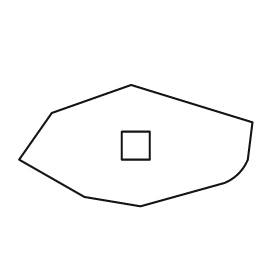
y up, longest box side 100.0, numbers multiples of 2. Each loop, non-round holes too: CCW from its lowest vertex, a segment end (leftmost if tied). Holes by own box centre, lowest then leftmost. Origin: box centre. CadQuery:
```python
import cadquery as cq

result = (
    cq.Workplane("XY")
    .moveTo(2.0, -26.0)
    .lineTo(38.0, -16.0)
    .threePointArc((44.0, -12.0), (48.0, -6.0))
    .lineTo(50.0, 10.0)
    .lineTo(-2.0, 26.0)
    .lineTo(-36.0, 14.0)
    .lineTo(-50.0, -6.0)
    .lineTo(-22.0, -22.0)
    .close()
    .moveTo(-6.0, -6.0)
    .lineTo(6.0, -6.0)
    .lineTo(6.0, 6.0)
    .lineTo(-6.0, 6.0)
    .close()
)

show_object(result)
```